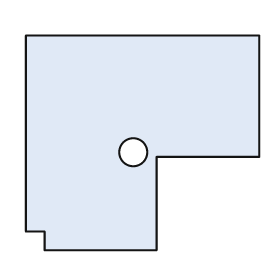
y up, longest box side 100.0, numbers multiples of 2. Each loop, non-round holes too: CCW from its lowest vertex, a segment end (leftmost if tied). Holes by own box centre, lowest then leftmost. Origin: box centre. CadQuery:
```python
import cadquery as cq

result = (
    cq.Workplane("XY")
    .moveTo(-42.0, -46.0)
    .lineTo(6.0, -46.0)
    .lineTo(6.0, -6.0)
    .lineTo(50.0, -6.0)
    .lineTo(50.0, 46.0)
    .lineTo(-50.0, 46.0)
    .lineTo(-50.0, -38.0)
    .lineTo(-42.0, -38.0)
    .close()
    .moveTo(-4.0, -4.0)
    .circle(6.0)
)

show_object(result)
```